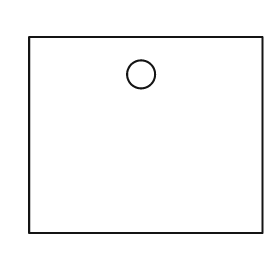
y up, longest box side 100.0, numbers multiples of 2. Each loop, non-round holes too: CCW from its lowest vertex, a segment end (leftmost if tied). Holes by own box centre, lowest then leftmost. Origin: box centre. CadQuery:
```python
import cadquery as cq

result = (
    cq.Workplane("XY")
    .moveTo(-50.0, -42.0)
    .lineTo(50.0, -42.0)
    .lineTo(50.0, 42.0)
    .lineTo(-50.0, 42.0)
    .close()
    .moveTo(-2.0, 26.0)
    .circle(6.0)
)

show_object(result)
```